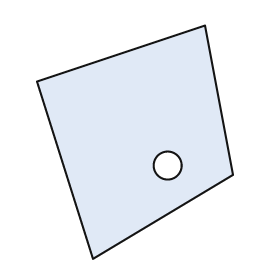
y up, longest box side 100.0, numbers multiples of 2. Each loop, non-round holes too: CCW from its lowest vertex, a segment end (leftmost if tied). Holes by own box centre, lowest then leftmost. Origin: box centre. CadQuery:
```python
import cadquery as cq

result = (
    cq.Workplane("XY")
    .moveTo(-18.0, -50.0)
    .lineTo(42.0, -14.0)
    .lineTo(30.0, 50.0)
    .lineTo(-42.0, 26.0)
    .close()
    .moveTo(14.0, -10.0)
    .circle(6.0)
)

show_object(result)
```